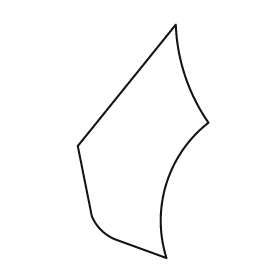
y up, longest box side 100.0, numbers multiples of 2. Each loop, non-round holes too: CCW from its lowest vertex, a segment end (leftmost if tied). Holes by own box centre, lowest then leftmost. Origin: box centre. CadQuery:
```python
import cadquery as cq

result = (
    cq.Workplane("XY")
    .moveTo(10.0, -50.0)
    .threePointArc((10.0, -18.0), (28.0, 8.0))
    .threePointArc((18.0, 28.0), (14.0, 50.0))
    .lineTo(-28.0, -2.0)
    .lineTo(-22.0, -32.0)
    .threePointArc((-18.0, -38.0), (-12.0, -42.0))
    .close()
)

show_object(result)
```